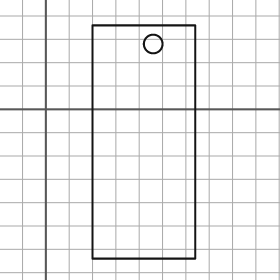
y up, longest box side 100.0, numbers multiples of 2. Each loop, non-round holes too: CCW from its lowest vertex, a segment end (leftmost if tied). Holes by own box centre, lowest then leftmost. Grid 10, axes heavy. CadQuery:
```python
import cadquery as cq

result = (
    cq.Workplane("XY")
    .moveTo(20.0, -64.0)
    .lineTo(64.0, -64.0)
    .lineTo(64.0, 36.0)
    .lineTo(20.0, 36.0)
    .close()
    .moveTo(46.0, 28.0)
    .circle(4.0)
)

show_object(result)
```